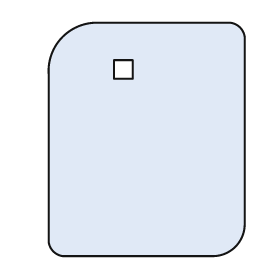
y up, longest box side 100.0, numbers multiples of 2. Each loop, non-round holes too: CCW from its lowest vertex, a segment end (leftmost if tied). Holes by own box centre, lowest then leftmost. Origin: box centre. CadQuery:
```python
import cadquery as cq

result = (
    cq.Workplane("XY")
    .moveTo(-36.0, -50.0)
    .lineTo(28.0, -50.0)
    .threePointArc((38.0, -46.0), (42.0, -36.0))
    .lineTo(42.0, 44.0)
    .threePointArc((40.0, 48.0), (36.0, 50.0))
    .lineTo(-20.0, 50.0)
    .threePointArc((-36.0, 44.0), (-42.0, 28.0))
    .lineTo(-42.0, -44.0)
    .threePointArc((-40.0, -48.0), (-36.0, -50.0))
    .close()
    .moveTo(-14.0, 26.0)
    .lineTo(-6.0, 26.0)
    .lineTo(-6.0, 34.0)
    .lineTo(-14.0, 34.0)
    .close()
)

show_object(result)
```